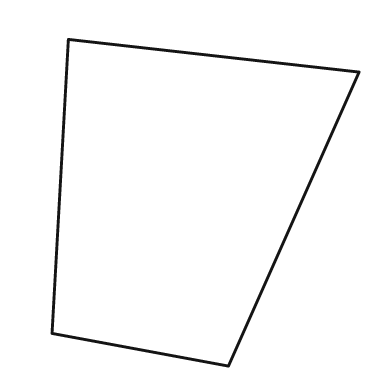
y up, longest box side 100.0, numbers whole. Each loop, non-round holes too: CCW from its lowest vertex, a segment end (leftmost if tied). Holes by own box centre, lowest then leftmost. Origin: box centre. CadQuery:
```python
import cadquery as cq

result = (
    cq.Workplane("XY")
    .moveTo(7.0, -50.0)
    .lineTo(47.0, 40.0)
    .lineTo(-42.0, 50.0)
    .lineTo(-47.0, -40.0)
    .close()
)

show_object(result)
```